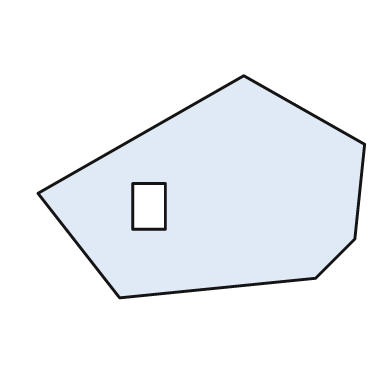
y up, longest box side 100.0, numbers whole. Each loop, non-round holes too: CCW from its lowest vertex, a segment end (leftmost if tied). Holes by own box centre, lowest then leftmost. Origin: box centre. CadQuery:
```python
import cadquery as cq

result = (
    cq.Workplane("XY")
    .moveTo(-25.0, -34.0)
    .lineTo(35.0, -28.0)
    .lineTo(47.0, -16.0)
    .lineTo(50.0, 13.0)
    .lineTo(13.0, 34.0)
    .lineTo(-50.0, -2.0)
    .close()
    .moveTo(-21.0, -13.0)
    .lineTo(-11.0, -13.0)
    .lineTo(-11.0, 1.0)
    .lineTo(-21.0, 1.0)
    .close()
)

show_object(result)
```